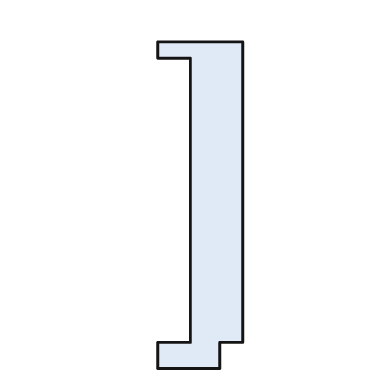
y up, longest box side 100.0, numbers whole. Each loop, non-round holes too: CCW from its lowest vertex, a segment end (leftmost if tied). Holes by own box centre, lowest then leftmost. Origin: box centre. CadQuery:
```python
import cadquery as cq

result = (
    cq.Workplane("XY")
    .moveTo(-13.0, -50.0)
    .lineTo(6.0, -50.0)
    .lineTo(6.0, -42.0)
    .lineTo(13.0, -42.0)
    .lineTo(13.0, 50.0)
    .lineTo(-13.0, 50.0)
    .lineTo(-13.0, 45.0)
    .lineTo(-3.0, 45.0)
    .lineTo(-3.0, -42.0)
    .lineTo(-13.0, -42.0)
    .close()
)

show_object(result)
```